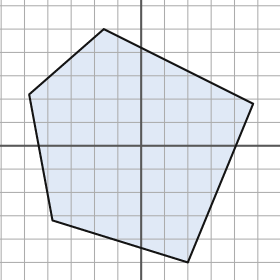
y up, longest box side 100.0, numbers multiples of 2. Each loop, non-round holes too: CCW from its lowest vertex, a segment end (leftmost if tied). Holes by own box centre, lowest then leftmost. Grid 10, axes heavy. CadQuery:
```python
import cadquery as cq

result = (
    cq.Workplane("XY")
    .moveTo(20.0, -50.0)
    .lineTo(48.0, 18.0)
    .lineTo(-16.0, 50.0)
    .lineTo(-48.0, 22.0)
    .lineTo(-38.0, -32.0)
    .close()
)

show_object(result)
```